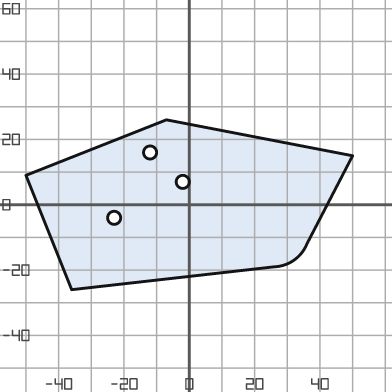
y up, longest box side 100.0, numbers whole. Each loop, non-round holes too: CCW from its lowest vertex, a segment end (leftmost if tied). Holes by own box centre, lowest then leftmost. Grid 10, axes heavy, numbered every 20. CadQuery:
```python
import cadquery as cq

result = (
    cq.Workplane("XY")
    .moveTo(-36.0, -26.0)
    .lineTo(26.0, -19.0)
    .threePointArc((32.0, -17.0), (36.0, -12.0))
    .lineTo(50.0, 15.0)
    .lineTo(-7.0, 26.0)
    .lineTo(-50.0, 9.0)
    .close()
    .moveTo(-23.0, -4.0)
    .circle(2.0)
    .moveTo(-2.0, 7.0)
    .circle(2.0)
    .moveTo(-12.0, 16.0)
    .circle(2.0)
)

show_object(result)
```